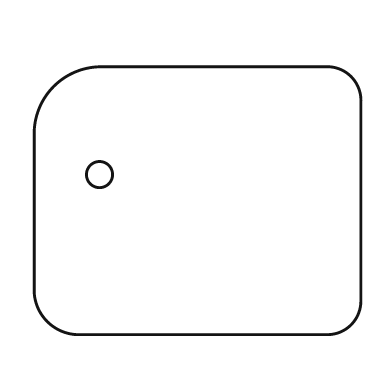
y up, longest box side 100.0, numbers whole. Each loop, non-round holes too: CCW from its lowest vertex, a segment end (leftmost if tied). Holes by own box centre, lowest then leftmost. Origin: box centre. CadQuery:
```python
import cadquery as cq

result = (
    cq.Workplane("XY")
    .moveTo(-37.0, -41.0)
    .lineTo(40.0, -41.0)
    .threePointArc((47.0, -38.0), (50.0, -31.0))
    .lineTo(50.0, 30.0)
    .threePointArc((47.0, 38.0), (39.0, 41.0))
    .lineTo(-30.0, 41.0)
    .threePointArc((-44.0, 35.0), (-50.0, 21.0))
    .lineTo(-50.0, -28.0)
    .threePointArc((-46.0, -37.0), (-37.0, -41.0))
    .close()
    .moveTo(-30.0, 8.0)
    .circle(4.0)
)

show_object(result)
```